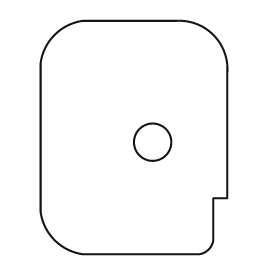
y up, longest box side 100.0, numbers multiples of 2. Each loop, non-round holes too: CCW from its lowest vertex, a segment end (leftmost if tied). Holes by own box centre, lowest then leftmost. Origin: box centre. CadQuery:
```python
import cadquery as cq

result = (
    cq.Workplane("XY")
    .moveTo(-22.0, -50.0)
    .lineTo(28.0, -50.0)
    .threePointArc((32.0, -48.0), (34.0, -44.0))
    .lineTo(34.0, -26.0)
    .lineTo(40.0, -26.0)
    .lineTo(40.0, 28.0)
    .threePointArc((34.0, 44.0), (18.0, 50.0))
    .lineTo(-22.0, 50.0)
    .threePointArc((-34.0, 44.0), (-40.0, 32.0))
    .lineTo(-40.0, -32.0)
    .threePointArc((-34.0, -44.0), (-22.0, -50.0))
    .close()
    .moveTo(8.0, -2.0)
    .circle(8.0)
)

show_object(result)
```